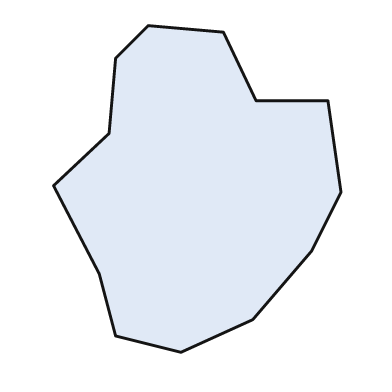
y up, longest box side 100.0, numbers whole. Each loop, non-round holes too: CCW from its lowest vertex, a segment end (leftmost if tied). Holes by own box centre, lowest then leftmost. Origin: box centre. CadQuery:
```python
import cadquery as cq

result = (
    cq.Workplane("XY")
    .moveTo(-5.0, -50.0)
    .lineTo(17.0, -40.0)
    .lineTo(35.0, -19.0)
    .lineTo(44.0, -1.0)
    .lineTo(40.0, 27.0)
    .lineTo(18.0, 27.0)
    .lineTo(8.0, 48.0)
    .lineTo(-15.0, 50.0)
    .lineTo(-25.0, 40.0)
    .lineTo(-27.0, 17.0)
    .lineTo(-44.0, 1.0)
    .lineTo(-30.0, -26.0)
    .lineTo(-25.0, -45.0)
    .close()
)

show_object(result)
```